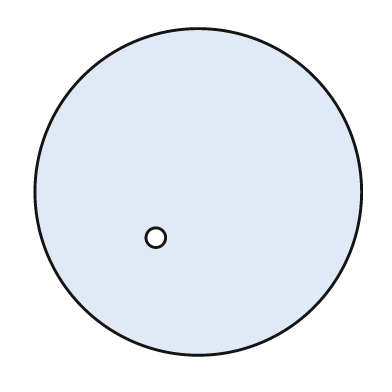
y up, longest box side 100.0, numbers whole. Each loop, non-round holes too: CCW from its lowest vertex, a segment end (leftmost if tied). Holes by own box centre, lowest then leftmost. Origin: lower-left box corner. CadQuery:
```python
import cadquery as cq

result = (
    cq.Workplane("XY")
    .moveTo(50.0, 50.0)
    .circle(50.0)
    .moveTo(37.0, 36.0)
    .circle(3.0)
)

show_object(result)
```